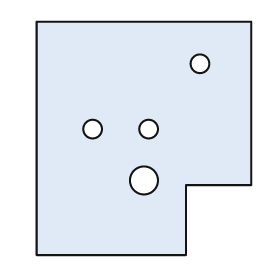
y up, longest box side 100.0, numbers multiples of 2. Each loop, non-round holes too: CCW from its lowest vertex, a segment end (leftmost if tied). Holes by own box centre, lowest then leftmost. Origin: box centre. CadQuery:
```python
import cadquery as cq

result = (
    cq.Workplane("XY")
    .moveTo(-46.0, -50.0)
    .lineTo(18.0, -50.0)
    .lineTo(18.0, -20.0)
    .lineTo(46.0, -20.0)
    .lineTo(46.0, 50.0)
    .lineTo(-46.0, 50.0)
    .close()
    .moveTo(0.0, -18.0)
    .circle(6.0)
    .moveTo(-22.0, 4.0)
    .circle(4.0)
    .moveTo(2.0, 4.0)
    .circle(4.0)
    .moveTo(24.0, 32.0)
    .circle(4.0)
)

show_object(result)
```